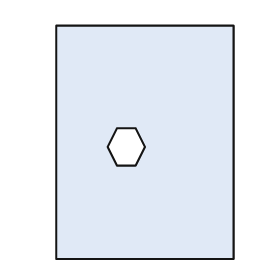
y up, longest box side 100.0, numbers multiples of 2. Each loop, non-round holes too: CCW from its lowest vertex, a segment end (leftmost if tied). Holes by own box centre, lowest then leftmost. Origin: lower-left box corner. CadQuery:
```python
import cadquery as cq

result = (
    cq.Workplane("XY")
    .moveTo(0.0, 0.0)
    .lineTo(76.0, 0.0)
    .lineTo(76.0, 100.0)
    .lineTo(0.0, 100.0)
    .close()
    .moveTo(26.0, 40.0)
    .lineTo(34.0, 40.0)
    .lineTo(38.0, 48.0)
    .lineTo(34.0, 56.0)
    .lineTo(26.0, 56.0)
    .lineTo(22.0, 48.0)
    .close()
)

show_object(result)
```